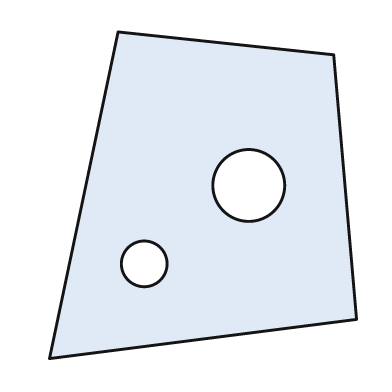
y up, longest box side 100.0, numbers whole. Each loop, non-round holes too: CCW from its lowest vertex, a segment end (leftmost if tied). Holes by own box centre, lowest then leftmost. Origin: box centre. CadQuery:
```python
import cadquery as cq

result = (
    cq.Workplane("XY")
    .moveTo(-47.0, -50.0)
    .lineTo(47.0, -38.0)
    .lineTo(40.0, 43.0)
    .lineTo(-26.0, 50.0)
    .close()
    .moveTo(-18.0, -21.0)
    .circle(7.0)
    .moveTo(14.0, 3.0)
    .circle(11.0)
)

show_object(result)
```